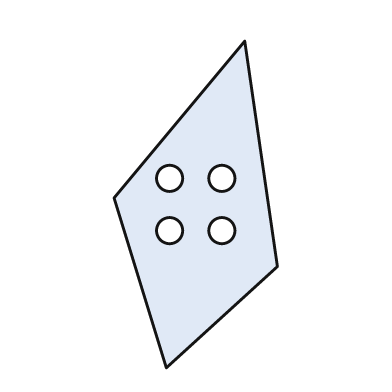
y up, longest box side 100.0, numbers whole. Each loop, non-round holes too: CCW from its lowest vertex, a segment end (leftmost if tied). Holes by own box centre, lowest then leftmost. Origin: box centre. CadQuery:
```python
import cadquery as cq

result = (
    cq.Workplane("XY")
    .moveTo(-9.0, -50.0)
    .lineTo(25.0, -19.0)
    .lineTo(15.0, 50.0)
    .lineTo(-25.0, 2.0)
    .close()
    .moveTo(-8.0, -8.0)
    .circle(4.0)
    .moveTo(8.0, -8.0)
    .circle(4.0)
    .moveTo(-8.0, 8.0)
    .circle(4.0)
    .moveTo(8.0, 8.0)
    .circle(4.0)
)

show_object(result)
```